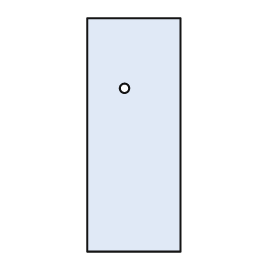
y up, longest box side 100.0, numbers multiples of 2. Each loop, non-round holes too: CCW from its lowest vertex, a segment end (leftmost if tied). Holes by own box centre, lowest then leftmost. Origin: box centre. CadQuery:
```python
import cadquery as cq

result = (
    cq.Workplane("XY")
    .moveTo(-20.0, -50.0)
    .lineTo(20.0, -50.0)
    .lineTo(20.0, 50.0)
    .lineTo(-20.0, 50.0)
    .close()
    .moveTo(-4.0, 20.0)
    .circle(2.0)
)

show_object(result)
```